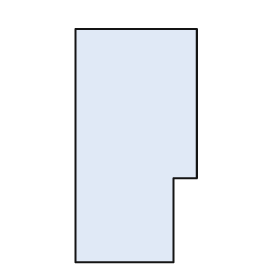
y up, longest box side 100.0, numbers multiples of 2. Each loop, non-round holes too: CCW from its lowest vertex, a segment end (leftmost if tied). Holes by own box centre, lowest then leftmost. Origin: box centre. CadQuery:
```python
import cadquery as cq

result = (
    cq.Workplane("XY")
    .moveTo(-26.0, -50.0)
    .lineTo(16.0, -50.0)
    .lineTo(16.0, -14.0)
    .lineTo(26.0, -14.0)
    .lineTo(26.0, 50.0)
    .lineTo(-26.0, 50.0)
    .close()
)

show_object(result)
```